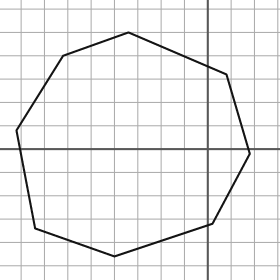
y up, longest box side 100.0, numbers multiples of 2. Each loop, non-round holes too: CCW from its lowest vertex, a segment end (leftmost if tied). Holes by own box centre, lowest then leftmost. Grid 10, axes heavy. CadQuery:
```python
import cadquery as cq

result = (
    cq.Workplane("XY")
    .moveTo(-40.0, -46.0)
    .lineTo(2.0, -32.0)
    .lineTo(18.0, -2.0)
    .lineTo(8.0, 32.0)
    .lineTo(-34.0, 50.0)
    .lineTo(-62.0, 40.0)
    .lineTo(-82.0, 8.0)
    .lineTo(-74.0, -34.0)
    .close()
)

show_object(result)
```